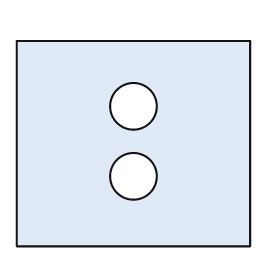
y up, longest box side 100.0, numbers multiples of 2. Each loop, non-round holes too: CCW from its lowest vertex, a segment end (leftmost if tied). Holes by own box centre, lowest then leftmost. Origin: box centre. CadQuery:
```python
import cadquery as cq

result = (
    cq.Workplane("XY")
    .moveTo(-50.0, -44.0)
    .lineTo(50.0, -44.0)
    .lineTo(50.0, 44.0)
    .lineTo(-50.0, 44.0)
    .close()
    .moveTo(0.0, -14.0)
    .circle(10.0)
    .moveTo(0.0, 16.0)
    .circle(10.0)
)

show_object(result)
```